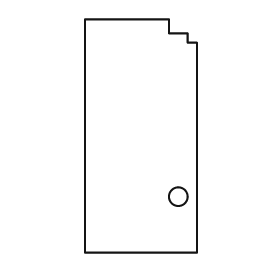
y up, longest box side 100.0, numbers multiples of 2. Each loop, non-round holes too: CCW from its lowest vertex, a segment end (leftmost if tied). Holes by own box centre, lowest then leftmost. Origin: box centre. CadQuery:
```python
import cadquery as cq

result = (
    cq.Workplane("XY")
    .moveTo(-24.0, -50.0)
    .lineTo(24.0, -50.0)
    .lineTo(24.0, 40.0)
    .lineTo(20.0, 40.0)
    .lineTo(20.0, 44.0)
    .lineTo(12.0, 44.0)
    .lineTo(12.0, 50.0)
    .lineTo(-24.0, 50.0)
    .close()
    .moveTo(16.0, -26.0)
    .circle(4.0)
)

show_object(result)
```